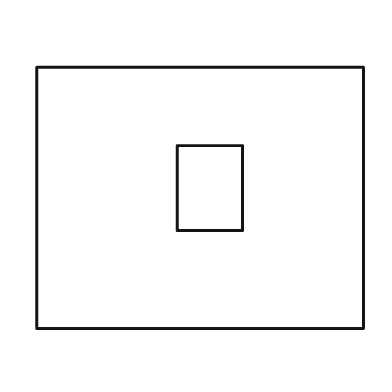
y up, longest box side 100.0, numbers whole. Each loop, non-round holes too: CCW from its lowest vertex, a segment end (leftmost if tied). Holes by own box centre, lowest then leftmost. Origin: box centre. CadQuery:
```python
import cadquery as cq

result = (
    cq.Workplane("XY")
    .moveTo(-50.0, -40.0)
    .lineTo(50.0, -40.0)
    .lineTo(50.0, 40.0)
    .lineTo(-50.0, 40.0)
    .close()
    .moveTo(-7.0, -10.0)
    .lineTo(13.0, -10.0)
    .lineTo(13.0, 16.0)
    .lineTo(-7.0, 16.0)
    .close()
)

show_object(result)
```